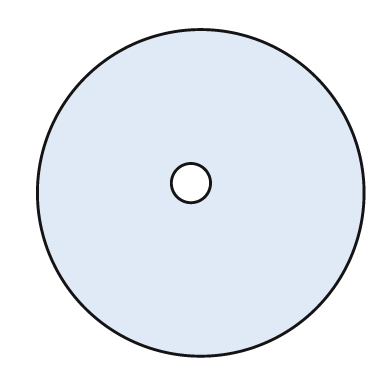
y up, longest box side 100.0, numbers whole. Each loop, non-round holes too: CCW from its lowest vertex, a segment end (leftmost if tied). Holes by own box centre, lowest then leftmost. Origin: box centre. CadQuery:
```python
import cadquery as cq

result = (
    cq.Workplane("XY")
    .moveTo(0.0, 0.0)
    .circle(50.0)
    .moveTo(-3.0, 3.0)
    .circle(6.0)
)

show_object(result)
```